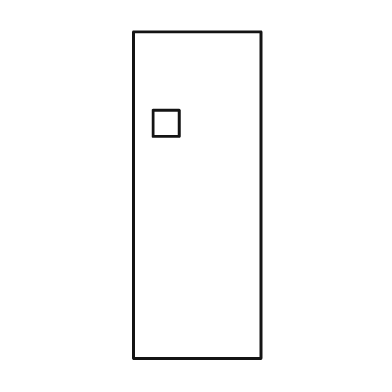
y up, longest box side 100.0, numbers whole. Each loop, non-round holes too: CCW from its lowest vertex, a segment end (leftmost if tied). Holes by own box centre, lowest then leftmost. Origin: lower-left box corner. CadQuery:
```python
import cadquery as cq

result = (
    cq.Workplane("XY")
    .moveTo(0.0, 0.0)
    .lineTo(39.0, 0.0)
    .lineTo(39.0, 100.0)
    .lineTo(0.0, 100.0)
    .close()
    .moveTo(6.0, 68.0)
    .lineTo(14.0, 68.0)
    .lineTo(14.0, 76.0)
    .lineTo(6.0, 76.0)
    .close()
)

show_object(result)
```